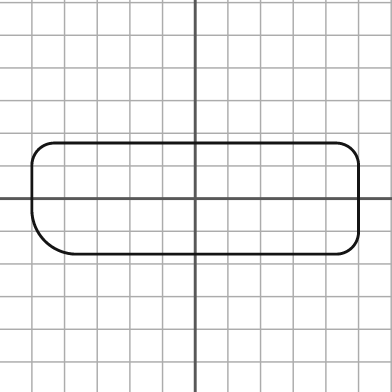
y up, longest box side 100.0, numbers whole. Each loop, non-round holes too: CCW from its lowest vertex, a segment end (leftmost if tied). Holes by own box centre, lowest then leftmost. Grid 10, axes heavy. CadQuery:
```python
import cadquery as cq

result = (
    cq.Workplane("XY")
    .moveTo(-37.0, -17.0)
    .lineTo(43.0, -17.0)
    .threePointArc((48.0, -15.0), (50.0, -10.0))
    .lineTo(50.0, 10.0)
    .threePointArc((48.0, 15.0), (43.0, 17.0))
    .lineTo(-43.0, 17.0)
    .threePointArc((-48.0, 15.0), (-50.0, 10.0))
    .lineTo(-50.0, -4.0)
    .threePointArc((-46.0, -13.0), (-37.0, -17.0))
    .close()
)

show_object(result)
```